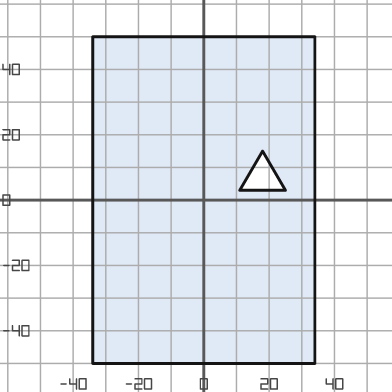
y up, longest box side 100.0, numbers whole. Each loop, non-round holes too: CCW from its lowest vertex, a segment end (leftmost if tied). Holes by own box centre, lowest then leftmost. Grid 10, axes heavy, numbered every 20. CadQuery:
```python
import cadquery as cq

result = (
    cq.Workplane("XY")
    .moveTo(-34.0, -50.0)
    .lineTo(34.0, -50.0)
    .lineTo(34.0, 50.0)
    .lineTo(-34.0, 50.0)
    .close()
    .moveTo(11.0, 3.0)
    .lineTo(25.0, 3.0)
    .lineTo(18.0, 15.0)
    .close()
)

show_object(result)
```